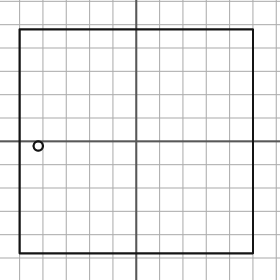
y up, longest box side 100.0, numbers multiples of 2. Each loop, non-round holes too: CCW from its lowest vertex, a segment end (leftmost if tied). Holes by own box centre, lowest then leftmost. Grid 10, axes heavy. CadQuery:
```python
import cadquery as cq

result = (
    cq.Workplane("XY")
    .moveTo(-50.0, -48.0)
    .lineTo(50.0, -48.0)
    .lineTo(50.0, 48.0)
    .lineTo(-50.0, 48.0)
    .close()
    .moveTo(-42.0, -2.0)
    .circle(2.0)
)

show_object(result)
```